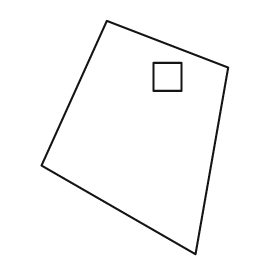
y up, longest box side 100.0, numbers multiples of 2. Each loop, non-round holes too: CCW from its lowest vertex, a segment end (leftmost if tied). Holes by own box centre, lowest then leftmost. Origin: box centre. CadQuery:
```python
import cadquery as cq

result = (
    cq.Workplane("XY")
    .moveTo(26.0, -50.0)
    .lineTo(40.0, 30.0)
    .lineTo(-12.0, 50.0)
    .lineTo(-40.0, -12.0)
    .close()
    .moveTo(8.0, 20.0)
    .lineTo(20.0, 20.0)
    .lineTo(20.0, 32.0)
    .lineTo(8.0, 32.0)
    .close()
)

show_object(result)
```